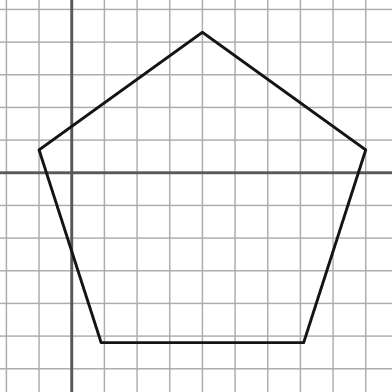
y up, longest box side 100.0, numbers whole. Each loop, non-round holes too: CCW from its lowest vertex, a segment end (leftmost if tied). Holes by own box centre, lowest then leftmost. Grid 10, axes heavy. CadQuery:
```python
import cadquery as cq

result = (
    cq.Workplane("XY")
    .moveTo(9.0, -52.0)
    .lineTo(71.0, -52.0)
    .lineTo(90.0, 7.0)
    .lineTo(40.0, 43.0)
    .lineTo(-10.0, 7.0)
    .close()
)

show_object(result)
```